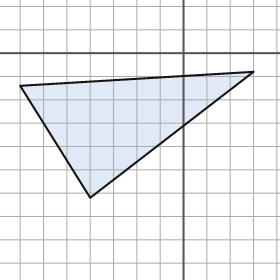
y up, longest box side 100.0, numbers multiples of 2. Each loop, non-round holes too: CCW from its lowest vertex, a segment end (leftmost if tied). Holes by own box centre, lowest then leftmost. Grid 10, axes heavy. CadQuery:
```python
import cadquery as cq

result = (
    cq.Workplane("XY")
    .moveTo(-40.0, -62.0)
    .lineTo(30.0, -8.0)
    .lineTo(-70.0, -14.0)
    .close()
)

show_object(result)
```